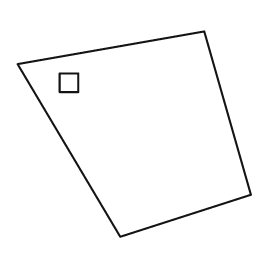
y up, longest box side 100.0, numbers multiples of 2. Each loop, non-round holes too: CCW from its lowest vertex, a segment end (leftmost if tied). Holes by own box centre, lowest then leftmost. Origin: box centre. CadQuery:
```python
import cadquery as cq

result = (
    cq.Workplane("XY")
    .moveTo(-6.0, -44.0)
    .lineTo(50.0, -26.0)
    .lineTo(30.0, 44.0)
    .lineTo(-50.0, 30.0)
    .close()
    .moveTo(-32.0, 18.0)
    .lineTo(-24.0, 18.0)
    .lineTo(-24.0, 26.0)
    .lineTo(-32.0, 26.0)
    .close()
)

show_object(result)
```